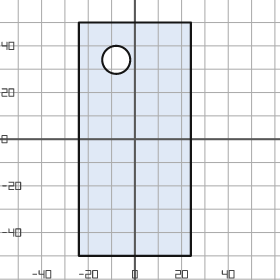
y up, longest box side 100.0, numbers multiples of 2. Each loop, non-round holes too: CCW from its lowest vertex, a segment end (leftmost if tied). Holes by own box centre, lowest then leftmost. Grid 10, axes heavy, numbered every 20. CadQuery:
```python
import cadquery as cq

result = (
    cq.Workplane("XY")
    .moveTo(-24.0, -50.0)
    .lineTo(24.0, -50.0)
    .lineTo(24.0, 50.0)
    .lineTo(-24.0, 50.0)
    .close()
    .moveTo(-8.0, 34.0)
    .circle(6.0)
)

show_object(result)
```